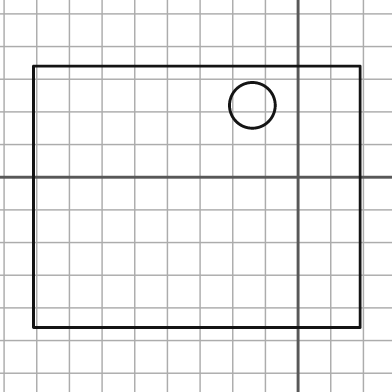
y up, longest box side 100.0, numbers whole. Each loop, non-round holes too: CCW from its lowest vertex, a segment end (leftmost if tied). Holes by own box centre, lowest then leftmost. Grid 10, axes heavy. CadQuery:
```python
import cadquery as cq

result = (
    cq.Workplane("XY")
    .moveTo(-81.0, -46.0)
    .lineTo(19.0, -46.0)
    .lineTo(19.0, 34.0)
    .lineTo(-81.0, 34.0)
    .close()
    .moveTo(-14.0, 22.0)
    .circle(7.0)
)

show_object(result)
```